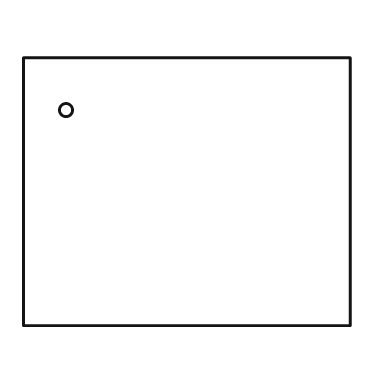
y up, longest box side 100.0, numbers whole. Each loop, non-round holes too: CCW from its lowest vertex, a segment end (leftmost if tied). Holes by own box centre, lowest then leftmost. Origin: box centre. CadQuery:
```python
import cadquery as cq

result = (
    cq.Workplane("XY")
    .moveTo(-50.0, -41.0)
    .lineTo(50.0, -41.0)
    .lineTo(50.0, 41.0)
    .lineTo(-50.0, 41.0)
    .close()
    .moveTo(-37.0, 25.0)
    .circle(2.0)
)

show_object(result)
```